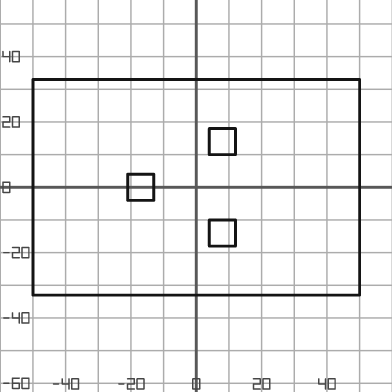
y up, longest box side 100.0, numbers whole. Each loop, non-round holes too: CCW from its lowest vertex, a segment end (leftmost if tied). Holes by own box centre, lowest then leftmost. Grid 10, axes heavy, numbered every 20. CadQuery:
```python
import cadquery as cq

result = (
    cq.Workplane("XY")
    .moveTo(-50.0, -33.0)
    .lineTo(50.0, -33.0)
    .lineTo(50.0, 33.0)
    .lineTo(-50.0, 33.0)
    .close()
    .moveTo(4.0, -18.0)
    .lineTo(12.0, -18.0)
    .lineTo(12.0, -10.0)
    .lineTo(4.0, -10.0)
    .close()
    .moveTo(-21.0, -4.0)
    .lineTo(-13.0, -4.0)
    .lineTo(-13.0, 4.0)
    .lineTo(-21.0, 4.0)
    .close()
    .moveTo(4.0, 10.0)
    .lineTo(12.0, 10.0)
    .lineTo(12.0, 18.0)
    .lineTo(4.0, 18.0)
    .close()
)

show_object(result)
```